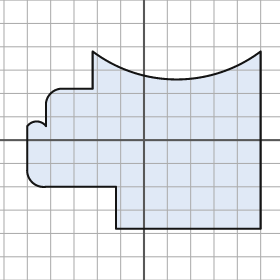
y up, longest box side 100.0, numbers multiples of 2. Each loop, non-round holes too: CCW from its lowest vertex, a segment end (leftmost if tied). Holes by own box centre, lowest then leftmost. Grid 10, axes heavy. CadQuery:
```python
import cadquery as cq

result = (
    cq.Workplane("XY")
    .moveTo(-12.0, -38.0)
    .lineTo(50.0, -38.0)
    .lineTo(50.0, 38.0)
    .threePointArc((14.0, 26.0), (-22.0, 38.0))
    .lineTo(-22.0, 22.0)
    .lineTo(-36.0, 22.0)
    .threePointArc((-40.0, 20.0), (-42.0, 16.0))
    .lineTo(-42.0, 6.0)
    .threePointArc((-46.0, 8.0), (-50.0, 6.0))
    .lineTo(-50.0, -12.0)
    .threePointArc((-48.0, -18.0), (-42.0, -20.0))
    .lineTo(-12.0, -20.0)
    .close()
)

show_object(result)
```